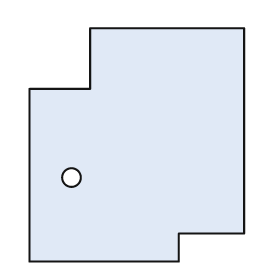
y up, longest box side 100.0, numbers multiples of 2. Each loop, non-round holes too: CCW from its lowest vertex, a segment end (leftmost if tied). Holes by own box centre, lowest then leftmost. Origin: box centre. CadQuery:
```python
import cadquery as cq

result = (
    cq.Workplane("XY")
    .moveTo(-46.0, -50.0)
    .lineTo(18.0, -50.0)
    .lineTo(18.0, -38.0)
    .lineTo(46.0, -38.0)
    .lineTo(46.0, 50.0)
    .lineTo(-20.0, 50.0)
    .lineTo(-20.0, 24.0)
    .lineTo(-46.0, 24.0)
    .close()
    .moveTo(-28.0, -14.0)
    .circle(4.0)
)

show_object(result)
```